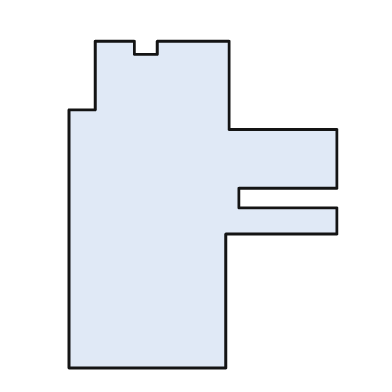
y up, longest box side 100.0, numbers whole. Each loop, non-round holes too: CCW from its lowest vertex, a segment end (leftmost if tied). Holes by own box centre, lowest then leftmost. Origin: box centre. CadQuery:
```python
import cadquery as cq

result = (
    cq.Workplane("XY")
    .moveTo(-41.0, -50.0)
    .lineTo(7.0, -50.0)
    .lineTo(7.0, -9.0)
    .lineTo(41.0, -9.0)
    .lineTo(41.0, -1.0)
    .lineTo(11.0, -1.0)
    .lineTo(11.0, 5.0)
    .lineTo(41.0, 5.0)
    .lineTo(41.0, 23.0)
    .lineTo(8.0, 23.0)
    .lineTo(8.0, 50.0)
    .lineTo(-14.0, 50.0)
    .lineTo(-14.0, 46.0)
    .lineTo(-21.0, 46.0)
    .lineTo(-21.0, 50.0)
    .lineTo(-33.0, 50.0)
    .lineTo(-33.0, 29.0)
    .lineTo(-41.0, 29.0)
    .close()
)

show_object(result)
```